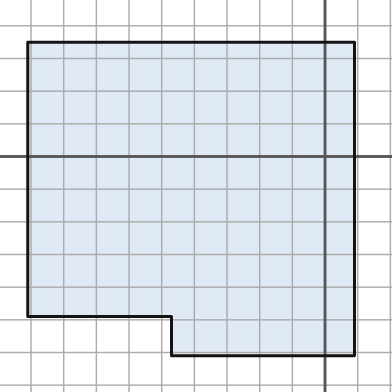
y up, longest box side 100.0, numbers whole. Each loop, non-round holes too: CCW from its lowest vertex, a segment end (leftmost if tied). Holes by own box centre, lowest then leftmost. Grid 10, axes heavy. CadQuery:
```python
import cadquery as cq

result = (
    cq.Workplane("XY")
    .moveTo(-47.0, -61.0)
    .lineTo(9.0, -61.0)
    .lineTo(9.0, 35.0)
    .lineTo(-91.0, 35.0)
    .lineTo(-91.0, -49.0)
    .lineTo(-47.0, -49.0)
    .close()
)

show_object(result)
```